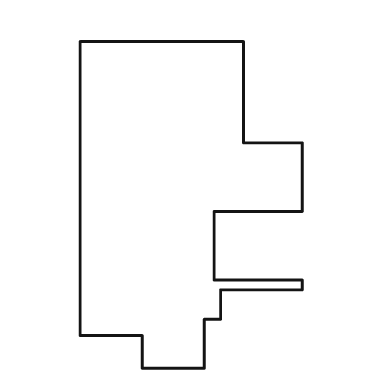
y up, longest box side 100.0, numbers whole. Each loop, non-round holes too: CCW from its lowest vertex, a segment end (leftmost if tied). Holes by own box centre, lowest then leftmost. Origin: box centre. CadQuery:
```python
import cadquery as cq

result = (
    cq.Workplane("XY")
    .moveTo(-15.0, -50.0)
    .lineTo(4.0, -50.0)
    .lineTo(4.0, -35.0)
    .lineTo(9.0, -35.0)
    .lineTo(9.0, -26.0)
    .lineTo(34.0, -26.0)
    .lineTo(34.0, -23.0)
    .lineTo(7.0, -23.0)
    .lineTo(7.0, -2.0)
    .lineTo(34.0, -2.0)
    .lineTo(34.0, 19.0)
    .lineTo(16.0, 19.0)
    .lineTo(16.0, 50.0)
    .lineTo(-34.0, 50.0)
    .lineTo(-34.0, -40.0)
    .lineTo(-15.0, -40.0)
    .close()
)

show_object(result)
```